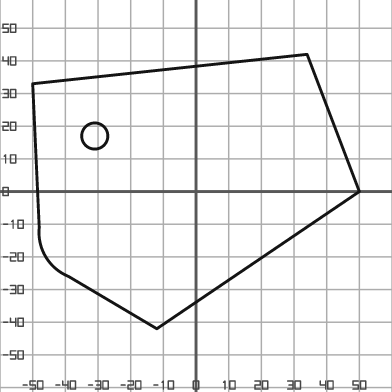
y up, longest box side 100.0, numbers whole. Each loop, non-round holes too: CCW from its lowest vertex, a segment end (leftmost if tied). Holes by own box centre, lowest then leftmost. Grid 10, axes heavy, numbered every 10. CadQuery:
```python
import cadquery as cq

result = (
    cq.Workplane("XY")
    .moveTo(-12.0, -42.0)
    .lineTo(50.0, 0.0)
    .lineTo(34.0, 42.0)
    .lineTo(-50.0, 33.0)
    .lineTo(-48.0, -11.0)
    .threePointArc((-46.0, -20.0), (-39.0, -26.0))
    .close()
    .moveTo(-31.0, 17.0)
    .circle(4.0)
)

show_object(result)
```